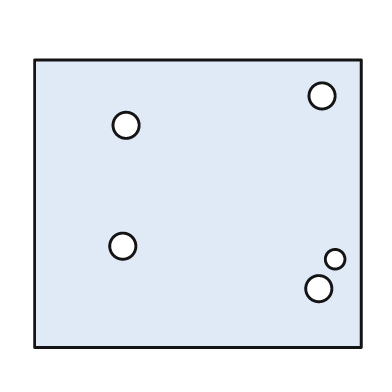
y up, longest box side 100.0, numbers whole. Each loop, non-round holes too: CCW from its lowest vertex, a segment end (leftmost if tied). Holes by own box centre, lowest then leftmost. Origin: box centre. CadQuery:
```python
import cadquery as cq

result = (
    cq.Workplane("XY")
    .moveTo(-50.0, -44.0)
    .lineTo(50.0, -44.0)
    .lineTo(50.0, 44.0)
    .lineTo(-50.0, 44.0)
    .close()
    .moveTo(37.0, -26.0)
    .circle(4.0)
    .moveTo(42.0, -17.0)
    .circle(3.0)
    .moveTo(-23.0, -13.0)
    .circle(4.0)
    .moveTo(-22.0, 24.0)
    .circle(4.0)
    .moveTo(38.0, 33.0)
    .circle(4.0)
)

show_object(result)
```